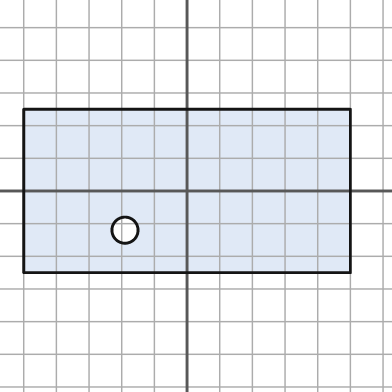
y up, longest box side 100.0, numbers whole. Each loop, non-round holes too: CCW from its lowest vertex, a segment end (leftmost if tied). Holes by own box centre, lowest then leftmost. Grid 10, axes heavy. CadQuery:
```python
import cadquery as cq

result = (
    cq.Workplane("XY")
    .moveTo(-50.0, -25.0)
    .lineTo(50.0, -25.0)
    .lineTo(50.0, 25.0)
    .lineTo(-50.0, 25.0)
    .close()
    .moveTo(-19.0, -12.0)
    .circle(4.0)
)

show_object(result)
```